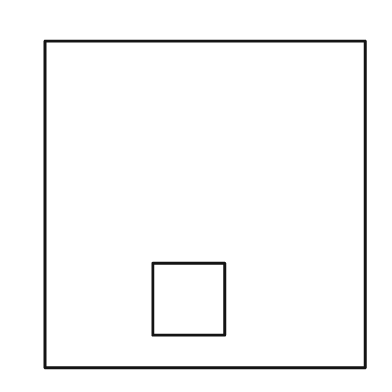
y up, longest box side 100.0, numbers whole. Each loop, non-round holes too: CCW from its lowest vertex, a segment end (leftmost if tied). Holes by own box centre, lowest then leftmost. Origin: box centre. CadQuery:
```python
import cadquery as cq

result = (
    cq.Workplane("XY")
    .moveTo(-49.0, -50.0)
    .lineTo(49.0, -50.0)
    .lineTo(49.0, 50.0)
    .lineTo(-49.0, 50.0)
    .close()
    .moveTo(-16.0, -40.0)
    .lineTo(6.0, -40.0)
    .lineTo(6.0, -18.0)
    .lineTo(-16.0, -18.0)
    .close()
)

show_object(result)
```